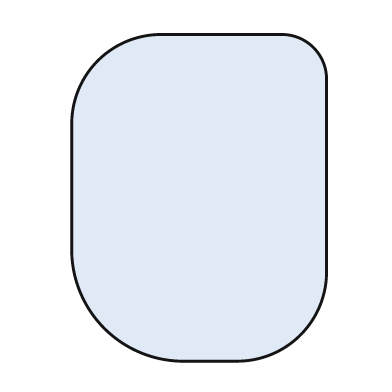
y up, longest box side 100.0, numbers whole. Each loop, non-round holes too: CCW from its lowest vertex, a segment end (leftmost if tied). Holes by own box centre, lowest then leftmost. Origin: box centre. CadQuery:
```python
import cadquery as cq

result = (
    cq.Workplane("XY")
    .moveTo(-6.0, -50.0)
    .lineTo(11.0, -50.0)
    .threePointArc((31.0, -42.0), (39.0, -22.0))
    .lineTo(39.0, 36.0)
    .threePointArc((35.0, 46.0), (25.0, 50.0))
    .lineTo(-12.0, 50.0)
    .threePointArc((-31.0, 42.0), (-39.0, 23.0))
    .lineTo(-39.0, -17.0)
    .threePointArc((-29.0, -40.0), (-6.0, -50.0))
    .close()
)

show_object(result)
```